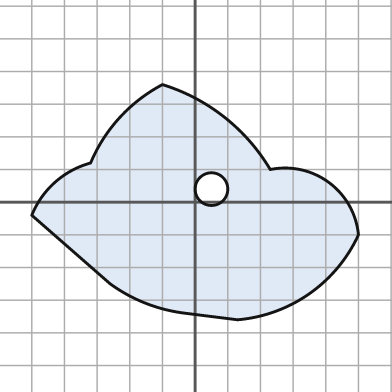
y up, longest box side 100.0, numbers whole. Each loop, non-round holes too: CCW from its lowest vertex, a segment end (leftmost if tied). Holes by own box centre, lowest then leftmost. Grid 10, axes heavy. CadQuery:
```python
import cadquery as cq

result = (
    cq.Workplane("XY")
    .moveTo(13.0, -36.0)
    .threePointArc((35.0, -28.0), (50.0, -10.0))
    .threePointArc((41.0, 6.0), (23.0, 10.0))
    .threePointArc((9.0, 26.0), (-10.0, 36.0))
    .threePointArc((-23.0, 26.0), (-32.0, 12.0))
    .threePointArc((-43.0, 6.0), (-50.0, -4.0))
    .lineTo(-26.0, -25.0)
    .threePointArc((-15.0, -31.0), (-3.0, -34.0))
    .close()
    .moveTo(5.0, 4.0)
    .circle(5.0)
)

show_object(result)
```